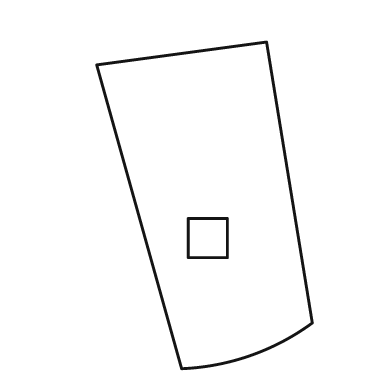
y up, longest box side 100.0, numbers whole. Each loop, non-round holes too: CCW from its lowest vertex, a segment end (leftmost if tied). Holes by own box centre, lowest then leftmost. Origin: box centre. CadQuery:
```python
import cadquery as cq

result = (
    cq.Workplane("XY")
    .moveTo(-7.0, -50.0)
    .threePointArc((14.0, -46.0), (33.0, -36.0))
    .lineTo(19.0, 50.0)
    .lineTo(-33.0, 43.0)
    .close()
    .moveTo(-5.0, -16.0)
    .lineTo(7.0, -16.0)
    .lineTo(7.0, -4.0)
    .lineTo(-5.0, -4.0)
    .close()
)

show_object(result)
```